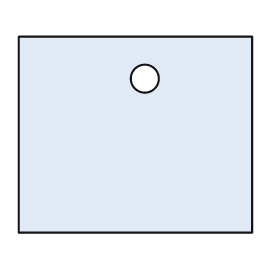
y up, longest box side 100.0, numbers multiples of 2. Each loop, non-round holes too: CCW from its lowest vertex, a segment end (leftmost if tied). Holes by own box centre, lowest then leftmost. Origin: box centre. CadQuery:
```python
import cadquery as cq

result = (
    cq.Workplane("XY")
    .moveTo(-50.0, -42.0)
    .lineTo(50.0, -42.0)
    .lineTo(50.0, 42.0)
    .lineTo(-50.0, 42.0)
    .close()
    .moveTo(4.0, 24.0)
    .circle(6.0)
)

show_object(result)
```